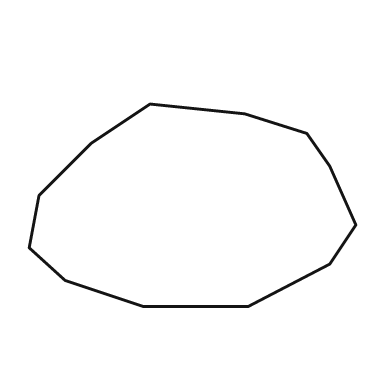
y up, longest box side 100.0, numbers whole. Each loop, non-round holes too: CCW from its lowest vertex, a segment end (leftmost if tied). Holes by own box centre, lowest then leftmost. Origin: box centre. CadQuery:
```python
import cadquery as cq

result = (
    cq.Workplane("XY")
    .moveTo(-15.0, -31.0)
    .lineTo(17.0, -31.0)
    .lineTo(42.0, -18.0)
    .lineTo(50.0, -6.0)
    .lineTo(42.0, 12.0)
    .lineTo(35.0, 22.0)
    .lineTo(16.0, 28.0)
    .lineTo(-13.0, 31.0)
    .lineTo(-31.0, 19.0)
    .lineTo(-47.0, 3.0)
    .lineTo(-50.0, -13.0)
    .lineTo(-39.0, -23.0)
    .close()
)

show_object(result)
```